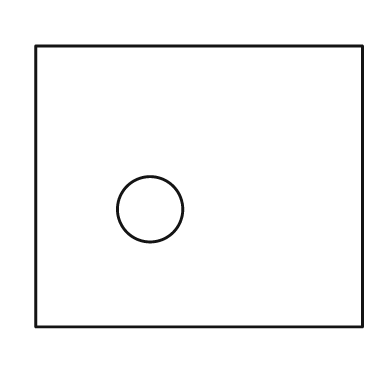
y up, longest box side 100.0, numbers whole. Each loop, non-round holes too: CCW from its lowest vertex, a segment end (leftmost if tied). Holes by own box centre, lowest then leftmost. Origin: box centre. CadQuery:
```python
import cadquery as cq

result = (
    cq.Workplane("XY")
    .moveTo(-50.0, -43.0)
    .lineTo(50.0, -43.0)
    .lineTo(50.0, 43.0)
    .lineTo(-50.0, 43.0)
    .close()
    .moveTo(-15.0, -7.0)
    .circle(10.0)
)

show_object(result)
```